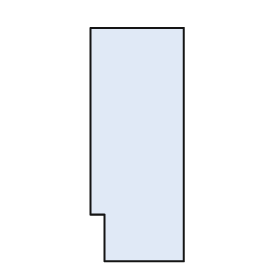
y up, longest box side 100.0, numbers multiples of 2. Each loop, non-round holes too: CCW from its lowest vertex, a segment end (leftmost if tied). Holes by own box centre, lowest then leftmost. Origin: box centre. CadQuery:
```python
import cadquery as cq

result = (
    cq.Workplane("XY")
    .moveTo(-14.0, -50.0)
    .lineTo(20.0, -50.0)
    .lineTo(20.0, 50.0)
    .lineTo(-20.0, 50.0)
    .lineTo(-20.0, -30.0)
    .lineTo(-14.0, -30.0)
    .close()
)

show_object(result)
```